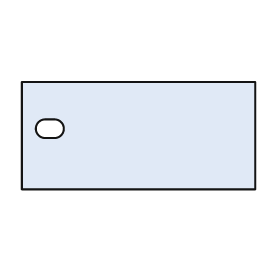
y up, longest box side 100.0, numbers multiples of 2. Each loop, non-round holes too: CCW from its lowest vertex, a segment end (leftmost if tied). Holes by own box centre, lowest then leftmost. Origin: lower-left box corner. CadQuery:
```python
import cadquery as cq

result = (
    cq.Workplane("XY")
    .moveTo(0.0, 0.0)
    .lineTo(100.0, 0.0)
    .lineTo(100.0, 46.0)
    .lineTo(0.0, 46.0)
    .close()
    .moveTo(10.0, 22.0)
    .lineTo(14.0, 22.0)
    .threePointArc((18.0, 26.0), (14.0, 30.0))
    .lineTo(10.0, 30.0)
    .threePointArc((6.0, 26.0), (10.0, 22.0))
    .close()
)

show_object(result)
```